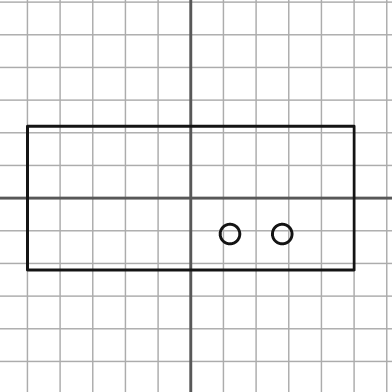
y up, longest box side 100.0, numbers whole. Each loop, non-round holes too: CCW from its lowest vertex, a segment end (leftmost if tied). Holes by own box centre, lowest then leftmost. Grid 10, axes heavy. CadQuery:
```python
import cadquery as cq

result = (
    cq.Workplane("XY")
    .moveTo(-50.0, -22.0)
    .lineTo(50.0, -22.0)
    .lineTo(50.0, 22.0)
    .lineTo(-50.0, 22.0)
    .close()
    .moveTo(12.0, -11.0)
    .circle(3.0)
    .moveTo(28.0, -11.0)
    .circle(3.0)
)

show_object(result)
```